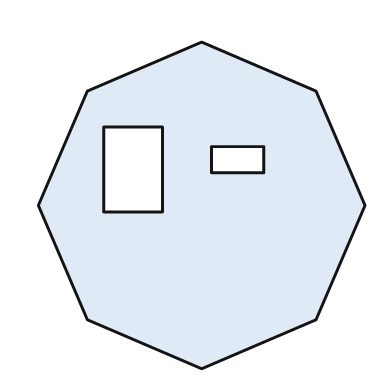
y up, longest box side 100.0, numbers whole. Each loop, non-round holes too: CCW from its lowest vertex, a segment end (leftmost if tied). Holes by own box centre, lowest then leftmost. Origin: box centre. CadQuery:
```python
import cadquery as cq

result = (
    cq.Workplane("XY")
    .moveTo(0.0, -50.0)
    .lineTo(35.0, -35.0)
    .lineTo(50.0, 0.0)
    .lineTo(35.0, 35.0)
    .lineTo(0.0, 50.0)
    .lineTo(-35.0, 35.0)
    .lineTo(-50.0, 0.0)
    .lineTo(-35.0, -35.0)
    .close()
    .moveTo(-30.0, -2.0)
    .lineTo(-12.0, -2.0)
    .lineTo(-12.0, 24.0)
    .lineTo(-30.0, 24.0)
    .close()
    .moveTo(3.0, 10.0)
    .lineTo(19.0, 10.0)
    .lineTo(19.0, 18.0)
    .lineTo(3.0, 18.0)
    .close()
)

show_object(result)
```